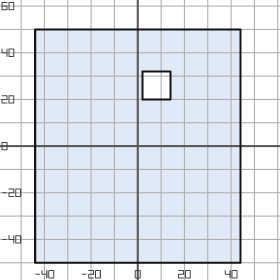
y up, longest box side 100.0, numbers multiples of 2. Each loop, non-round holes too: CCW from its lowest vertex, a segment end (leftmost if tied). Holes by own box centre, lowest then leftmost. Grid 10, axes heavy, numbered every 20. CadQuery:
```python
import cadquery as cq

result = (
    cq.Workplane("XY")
    .moveTo(-44.0, -50.0)
    .lineTo(44.0, -50.0)
    .lineTo(44.0, 50.0)
    .lineTo(-44.0, 50.0)
    .close()
    .moveTo(2.0, 20.0)
    .lineTo(14.0, 20.0)
    .lineTo(14.0, 32.0)
    .lineTo(2.0, 32.0)
    .close()
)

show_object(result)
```